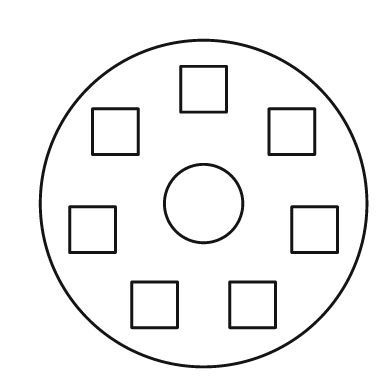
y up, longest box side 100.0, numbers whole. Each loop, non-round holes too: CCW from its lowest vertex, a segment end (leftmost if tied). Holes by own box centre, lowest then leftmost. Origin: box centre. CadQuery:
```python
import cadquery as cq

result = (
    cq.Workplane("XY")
    .moveTo(0.0, 0.0)
    .circle(50.0)
    .moveTo(-22.0, -38.0)
    .lineTo(-8.0, -38.0)
    .lineTo(-8.0, -24.0)
    .lineTo(-22.0, -24.0)
    .close()
    .moveTo(8.0, -38.0)
    .lineTo(22.0, -38.0)
    .lineTo(22.0, -24.0)
    .lineTo(8.0, -24.0)
    .close()
    .moveTo(-41.0, -15.0)
    .lineTo(-27.0, -15.0)
    .lineTo(-27.0, -1.0)
    .lineTo(-41.0, -1.0)
    .close()
    .moveTo(27.0, -15.0)
    .lineTo(41.0, -15.0)
    .lineTo(41.0, -1.0)
    .lineTo(27.0, -1.0)
    .close()
    .moveTo(0.0, 0.0)
    .circle(12.0)
    .moveTo(-34.0, 15.0)
    .lineTo(-20.0, 15.0)
    .lineTo(-20.0, 29.0)
    .lineTo(-34.0, 29.0)
    .close()
    .moveTo(20.0, 15.0)
    .lineTo(34.0, 15.0)
    .lineTo(34.0, 29.0)
    .lineTo(20.0, 29.0)
    .close()
    .moveTo(-7.0, 28.0)
    .lineTo(7.0, 28.0)
    .lineTo(7.0, 42.0)
    .lineTo(-7.0, 42.0)
    .close()
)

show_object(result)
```